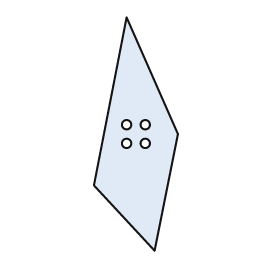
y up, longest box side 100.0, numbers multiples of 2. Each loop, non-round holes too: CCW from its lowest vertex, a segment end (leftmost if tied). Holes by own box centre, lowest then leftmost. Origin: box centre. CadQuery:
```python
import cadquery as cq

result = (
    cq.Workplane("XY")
    .moveTo(8.0, -50.0)
    .lineTo(18.0, 0.0)
    .lineTo(-4.0, 50.0)
    .lineTo(-18.0, -22.0)
    .close()
    .moveTo(-4.0, -4.0)
    .circle(2.0)
    .moveTo(4.0, -4.0)
    .circle(2.0)
    .moveTo(-4.0, 4.0)
    .circle(2.0)
    .moveTo(4.0, 4.0)
    .circle(2.0)
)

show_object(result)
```